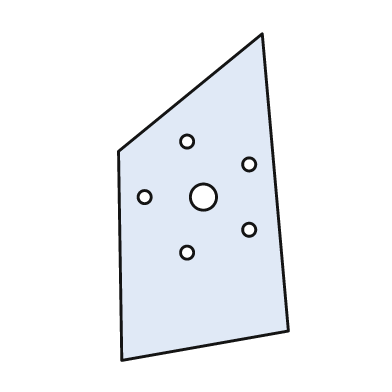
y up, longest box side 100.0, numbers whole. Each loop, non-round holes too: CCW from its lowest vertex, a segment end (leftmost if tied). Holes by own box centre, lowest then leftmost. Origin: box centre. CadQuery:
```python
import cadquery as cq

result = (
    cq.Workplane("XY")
    .moveTo(-25.0, -50.0)
    .lineTo(26.0, -41.0)
    .lineTo(18.0, 50.0)
    .lineTo(-26.0, 14.0)
    .close()
    .moveTo(-5.0, -17.0)
    .circle(2.0)
    .moveTo(14.0, -10.0)
    .circle(2.0)
    .moveTo(-18.0, 0.0)
    .circle(2.0)
    .moveTo(0.0, 0.0)
    .circle(4.0)
    .moveTo(14.0, 10.0)
    .circle(2.0)
    .moveTo(-5.0, 17.0)
    .circle(2.0)
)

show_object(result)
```